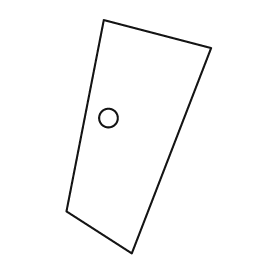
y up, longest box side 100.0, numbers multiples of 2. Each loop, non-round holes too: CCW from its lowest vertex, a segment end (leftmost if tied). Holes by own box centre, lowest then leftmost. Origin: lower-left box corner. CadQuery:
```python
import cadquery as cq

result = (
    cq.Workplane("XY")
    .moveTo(28.0, 0.0)
    .lineTo(62.0, 88.0)
    .lineTo(16.0, 100.0)
    .lineTo(0.0, 18.0)
    .close()
    .moveTo(18.0, 58.0)
    .circle(4.0)
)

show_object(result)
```